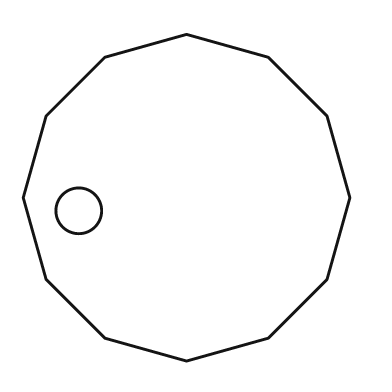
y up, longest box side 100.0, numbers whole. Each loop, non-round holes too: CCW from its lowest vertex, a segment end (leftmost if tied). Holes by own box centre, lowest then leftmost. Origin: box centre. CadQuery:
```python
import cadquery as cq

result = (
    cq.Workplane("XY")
    .moveTo(0.0, -50.0)
    .lineTo(25.0, -43.0)
    .lineTo(43.0, -25.0)
    .lineTo(50.0, 0.0)
    .lineTo(43.0, 25.0)
    .lineTo(25.0, 43.0)
    .lineTo(0.0, 50.0)
    .lineTo(-25.0, 43.0)
    .lineTo(-43.0, 25.0)
    .lineTo(-50.0, 0.0)
    .lineTo(-43.0, -25.0)
    .lineTo(-25.0, -43.0)
    .close()
    .moveTo(-33.0, -4.0)
    .circle(7.0)
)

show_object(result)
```